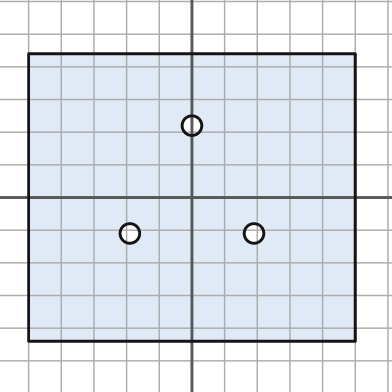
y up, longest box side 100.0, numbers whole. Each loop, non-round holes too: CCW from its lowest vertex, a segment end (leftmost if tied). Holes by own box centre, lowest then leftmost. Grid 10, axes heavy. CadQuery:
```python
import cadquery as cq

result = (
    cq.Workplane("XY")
    .moveTo(-50.0, -44.0)
    .lineTo(50.0, -44.0)
    .lineTo(50.0, 44.0)
    .lineTo(-50.0, 44.0)
    .close()
    .moveTo(-19.0, -11.0)
    .circle(3.0)
    .moveTo(19.0, -11.0)
    .circle(3.0)
    .moveTo(0.0, 22.0)
    .circle(3.0)
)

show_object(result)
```